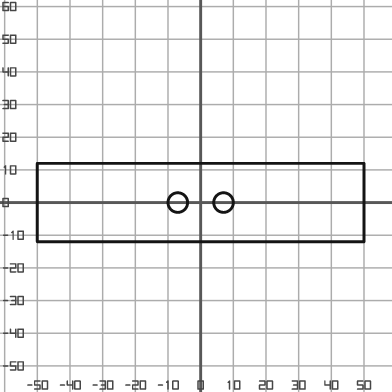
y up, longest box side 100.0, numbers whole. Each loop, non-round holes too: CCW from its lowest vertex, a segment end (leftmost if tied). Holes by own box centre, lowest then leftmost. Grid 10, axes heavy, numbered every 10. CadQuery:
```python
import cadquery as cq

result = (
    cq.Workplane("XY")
    .moveTo(-50.0, -12.0)
    .lineTo(50.0, -12.0)
    .lineTo(50.0, 12.0)
    .lineTo(-50.0, 12.0)
    .close()
    .moveTo(-7.0, 0.0)
    .circle(3.0)
    .moveTo(7.0, 0.0)
    .circle(3.0)
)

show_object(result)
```